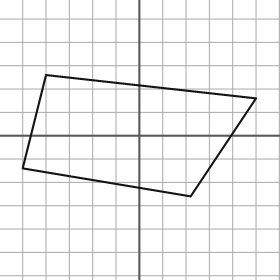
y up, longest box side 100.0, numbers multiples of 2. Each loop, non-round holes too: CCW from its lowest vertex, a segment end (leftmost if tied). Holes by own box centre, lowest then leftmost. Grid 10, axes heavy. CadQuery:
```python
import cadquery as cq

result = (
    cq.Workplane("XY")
    .moveTo(22.0, -26.0)
    .lineTo(50.0, 16.0)
    .lineTo(-40.0, 26.0)
    .lineTo(-50.0, -14.0)
    .close()
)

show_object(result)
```